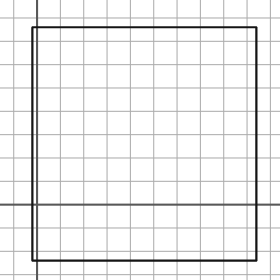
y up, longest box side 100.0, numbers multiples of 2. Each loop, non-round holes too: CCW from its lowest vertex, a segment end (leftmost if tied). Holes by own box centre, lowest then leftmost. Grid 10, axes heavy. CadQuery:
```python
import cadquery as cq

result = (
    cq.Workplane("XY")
    .moveTo(-2.0, -24.0)
    .lineTo(94.0, -24.0)
    .lineTo(94.0, 76.0)
    .lineTo(-2.0, 76.0)
    .close()
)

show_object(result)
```